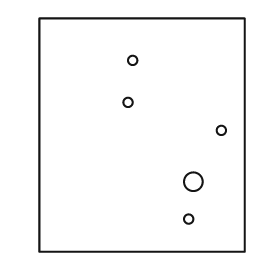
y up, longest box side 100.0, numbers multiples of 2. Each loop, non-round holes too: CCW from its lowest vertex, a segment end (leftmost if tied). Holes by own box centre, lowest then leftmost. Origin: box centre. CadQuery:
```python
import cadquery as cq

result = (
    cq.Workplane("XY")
    .moveTo(-44.0, -50.0)
    .lineTo(44.0, -50.0)
    .lineTo(44.0, 50.0)
    .lineTo(-44.0, 50.0)
    .close()
    .moveTo(20.0, -36.0)
    .circle(2.0)
    .moveTo(22.0, -20.0)
    .circle(4.0)
    .moveTo(34.0, 2.0)
    .circle(2.0)
    .moveTo(-6.0, 14.0)
    .circle(2.0)
    .moveTo(-4.0, 32.0)
    .circle(2.0)
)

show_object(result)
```